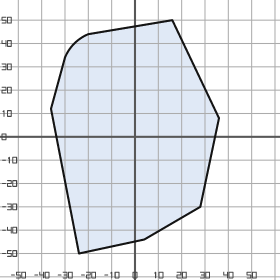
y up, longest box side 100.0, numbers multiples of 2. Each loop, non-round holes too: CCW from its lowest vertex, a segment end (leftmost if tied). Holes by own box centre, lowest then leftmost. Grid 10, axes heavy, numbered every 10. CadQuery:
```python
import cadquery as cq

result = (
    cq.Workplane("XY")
    .moveTo(-24.0, -50.0)
    .lineTo(4.0, -44.0)
    .lineTo(28.0, -30.0)
    .lineTo(36.0, 8.0)
    .lineTo(16.0, 50.0)
    .lineTo(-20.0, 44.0)
    .threePointArc((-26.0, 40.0), (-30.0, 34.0))
    .lineTo(-36.0, 12.0)
    .close()
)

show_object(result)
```